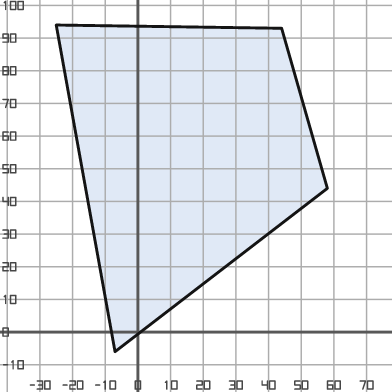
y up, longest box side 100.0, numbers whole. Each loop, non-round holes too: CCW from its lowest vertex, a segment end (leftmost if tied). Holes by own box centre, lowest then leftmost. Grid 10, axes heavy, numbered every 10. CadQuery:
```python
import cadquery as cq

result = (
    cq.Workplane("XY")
    .moveTo(-7.0, -6.0)
    .lineTo(58.0, 44.0)
    .lineTo(44.0, 93.0)
    .lineTo(-25.0, 94.0)
    .close()
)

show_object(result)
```